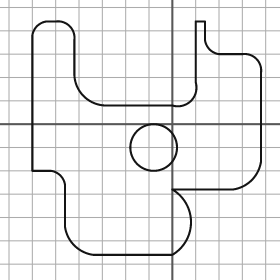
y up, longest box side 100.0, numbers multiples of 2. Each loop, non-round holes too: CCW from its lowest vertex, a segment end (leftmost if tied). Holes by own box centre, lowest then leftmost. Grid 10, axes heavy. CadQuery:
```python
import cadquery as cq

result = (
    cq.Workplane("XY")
    .moveTo(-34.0, -56.0)
    .lineTo(0.0, -56.0)
    .threePointArc((8.0, -42.0), (0.0, -28.0))
    .lineTo(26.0, -28.0)
    .threePointArc((34.0, -24.0), (38.0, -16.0))
    .lineTo(38.0, 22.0)
    .threePointArc((36.0, 28.0), (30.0, 30.0))
    .lineTo(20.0, 30.0)
    .threePointArc((16.0, 32.0), (14.0, 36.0))
    .lineTo(14.0, 44.0)
    .lineTo(10.0, 44.0)
    .lineTo(10.0, 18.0)
    .threePointArc((8.0, 10.0), (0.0, 8.0))
    .lineTo(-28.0, 8.0)
    .threePointArc((-38.0, 12.0), (-42.0, 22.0))
    .lineTo(-42.0, 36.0)
    .threePointArc((-44.0, 42.0), (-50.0, 44.0))
    .lineTo(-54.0, 44.0)
    .threePointArc((-58.0, 42.0), (-60.0, 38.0))
    .lineTo(-60.0, -20.0)
    .lineTo(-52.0, -20.0)
    .threePointArc((-48.0, -22.0), (-46.0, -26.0))
    .lineTo(-46.0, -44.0)
    .threePointArc((-42.0, -52.0), (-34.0, -56.0))
    .close()
    .moveTo(-8.0, -10.0)
    .circle(10.0)
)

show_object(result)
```